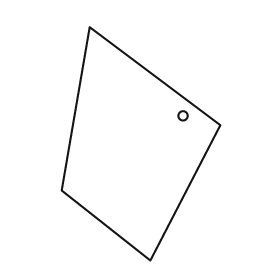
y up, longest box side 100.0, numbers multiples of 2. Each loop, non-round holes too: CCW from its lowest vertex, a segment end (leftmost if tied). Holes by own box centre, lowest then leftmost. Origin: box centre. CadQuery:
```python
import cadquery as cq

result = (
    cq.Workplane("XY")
    .moveTo(4.0, -50.0)
    .lineTo(34.0, 8.0)
    .lineTo(-22.0, 50.0)
    .lineTo(-34.0, -20.0)
    .close()
    .moveTo(18.0, 12.0)
    .circle(2.0)
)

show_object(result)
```